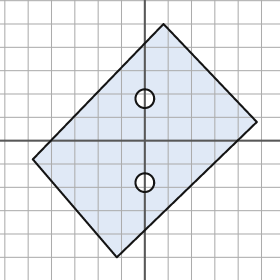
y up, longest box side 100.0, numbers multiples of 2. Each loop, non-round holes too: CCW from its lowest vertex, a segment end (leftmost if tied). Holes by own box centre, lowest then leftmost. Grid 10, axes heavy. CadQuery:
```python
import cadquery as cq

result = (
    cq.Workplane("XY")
    .moveTo(-12.0, -50.0)
    .lineTo(48.0, 8.0)
    .lineTo(8.0, 50.0)
    .lineTo(-48.0, -8.0)
    .close()
    .moveTo(0.0, -18.0)
    .circle(4.0)
    .moveTo(0.0, 18.0)
    .circle(4.0)
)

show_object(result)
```